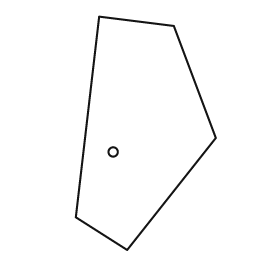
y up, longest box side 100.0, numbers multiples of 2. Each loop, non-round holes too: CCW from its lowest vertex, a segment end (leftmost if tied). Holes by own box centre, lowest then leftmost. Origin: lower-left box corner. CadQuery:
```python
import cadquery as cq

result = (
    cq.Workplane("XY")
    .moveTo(22.0, 0.0)
    .lineTo(60.0, 48.0)
    .lineTo(42.0, 96.0)
    .lineTo(10.0, 100.0)
    .lineTo(0.0, 14.0)
    .close()
    .moveTo(16.0, 42.0)
    .circle(2.0)
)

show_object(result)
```